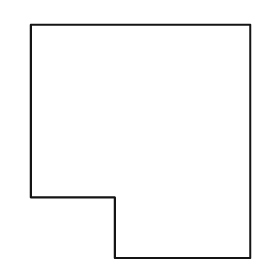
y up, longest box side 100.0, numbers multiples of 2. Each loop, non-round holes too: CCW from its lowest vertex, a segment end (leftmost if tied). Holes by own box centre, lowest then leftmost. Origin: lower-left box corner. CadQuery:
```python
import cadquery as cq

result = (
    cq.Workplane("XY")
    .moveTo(36.0, 0.0)
    .lineTo(94.0, 0.0)
    .lineTo(94.0, 100.0)
    .lineTo(0.0, 100.0)
    .lineTo(0.0, 26.0)
    .lineTo(36.0, 26.0)
    .close()
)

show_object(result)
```